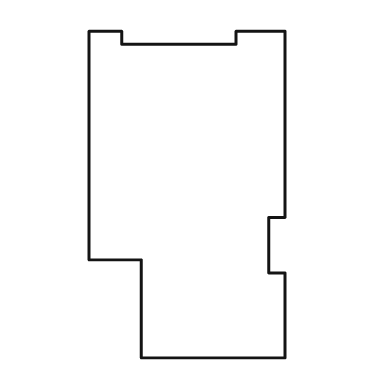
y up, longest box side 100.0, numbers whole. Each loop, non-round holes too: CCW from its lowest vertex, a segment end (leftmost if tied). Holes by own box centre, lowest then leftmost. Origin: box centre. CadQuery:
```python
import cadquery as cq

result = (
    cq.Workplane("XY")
    .moveTo(-14.0, -50.0)
    .lineTo(30.0, -50.0)
    .lineTo(30.0, -24.0)
    .lineTo(25.0, -24.0)
    .lineTo(25.0, -7.0)
    .lineTo(30.0, -7.0)
    .lineTo(30.0, 50.0)
    .lineTo(15.0, 50.0)
    .lineTo(15.0, 46.0)
    .lineTo(-20.0, 46.0)
    .lineTo(-20.0, 50.0)
    .lineTo(-30.0, 50.0)
    .lineTo(-30.0, -20.0)
    .lineTo(-14.0, -20.0)
    .close()
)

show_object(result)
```